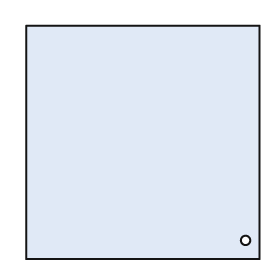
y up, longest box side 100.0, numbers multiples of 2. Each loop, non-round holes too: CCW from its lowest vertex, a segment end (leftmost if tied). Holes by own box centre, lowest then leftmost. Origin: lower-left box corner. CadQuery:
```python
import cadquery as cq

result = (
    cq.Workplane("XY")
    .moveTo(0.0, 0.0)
    .lineTo(100.0, 0.0)
    .lineTo(100.0, 100.0)
    .lineTo(0.0, 100.0)
    .close()
    .moveTo(94.0, 8.0)
    .circle(2.0)
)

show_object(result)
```